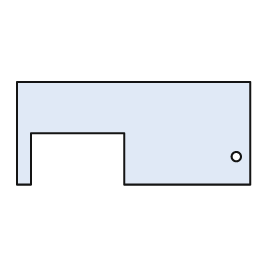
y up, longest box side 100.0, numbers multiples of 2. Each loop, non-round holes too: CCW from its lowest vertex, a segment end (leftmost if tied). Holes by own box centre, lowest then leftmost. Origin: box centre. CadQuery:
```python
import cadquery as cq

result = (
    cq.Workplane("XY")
    .moveTo(-50.0, -22.0)
    .lineTo(-44.0, -22.0)
    .lineTo(-44.0, 0.0)
    .lineTo(-4.0, 0.0)
    .lineTo(-4.0, -22.0)
    .lineTo(50.0, -22.0)
    .lineTo(50.0, 22.0)
    .lineTo(-50.0, 22.0)
    .close()
    .moveTo(44.0, -10.0)
    .circle(2.0)
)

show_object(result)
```